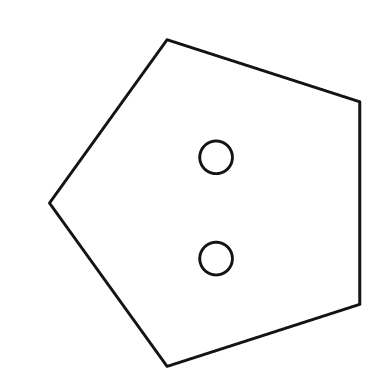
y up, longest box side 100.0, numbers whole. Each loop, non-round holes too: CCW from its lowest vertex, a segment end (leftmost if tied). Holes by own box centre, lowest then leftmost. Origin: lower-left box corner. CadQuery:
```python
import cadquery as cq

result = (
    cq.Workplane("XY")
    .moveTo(36.0, 0.0)
    .lineTo(95.0, 19.0)
    .lineTo(95.0, 81.0)
    .lineTo(36.0, 100.0)
    .lineTo(0.0, 50.0)
    .close()
    .moveTo(51.0, 33.0)
    .circle(5.0)
    .moveTo(51.0, 64.0)
    .circle(5.0)
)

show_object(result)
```